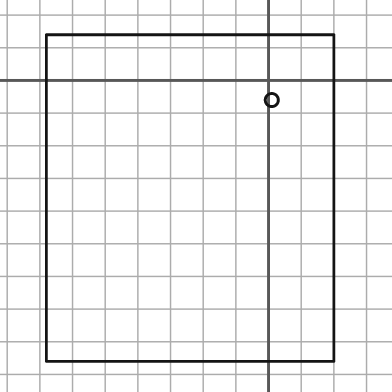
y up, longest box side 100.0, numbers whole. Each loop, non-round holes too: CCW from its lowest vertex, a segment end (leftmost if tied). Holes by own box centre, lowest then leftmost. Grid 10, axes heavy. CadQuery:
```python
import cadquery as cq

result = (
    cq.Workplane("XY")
    .moveTo(-68.0, -86.0)
    .lineTo(20.0, -86.0)
    .lineTo(20.0, 14.0)
    .lineTo(-68.0, 14.0)
    .close()
    .moveTo(1.0, -6.0)
    .circle(2.0)
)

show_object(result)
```